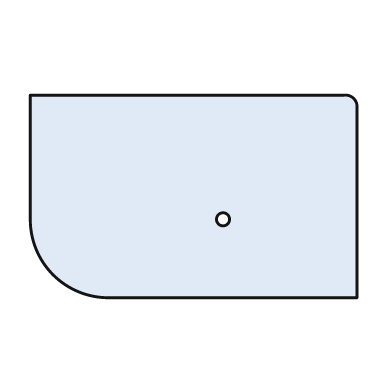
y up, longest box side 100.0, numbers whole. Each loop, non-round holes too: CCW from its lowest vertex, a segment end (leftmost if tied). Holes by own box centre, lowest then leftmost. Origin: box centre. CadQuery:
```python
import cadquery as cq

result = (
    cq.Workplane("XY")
    .moveTo(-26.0, -31.0)
    .lineTo(50.0, -31.0)
    .lineTo(50.0, 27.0)
    .threePointArc((49.0, 30.0), (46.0, 31.0))
    .lineTo(-50.0, 31.0)
    .lineTo(-50.0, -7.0)
    .threePointArc((-43.0, -24.0), (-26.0, -31.0))
    .close()
    .moveTo(9.0, -7.0)
    .circle(2.0)
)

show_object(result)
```